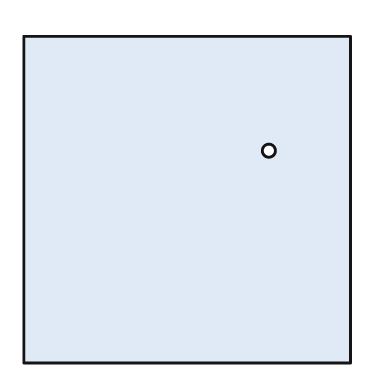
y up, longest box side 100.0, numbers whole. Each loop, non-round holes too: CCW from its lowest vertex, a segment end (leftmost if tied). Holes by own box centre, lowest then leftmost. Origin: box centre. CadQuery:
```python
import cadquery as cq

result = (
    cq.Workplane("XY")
    .moveTo(-50.0, -50.0)
    .lineTo(50.0, -50.0)
    .lineTo(50.0, 50.0)
    .lineTo(-50.0, 50.0)
    .close()
    .moveTo(25.0, 15.0)
    .circle(2.0)
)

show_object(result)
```